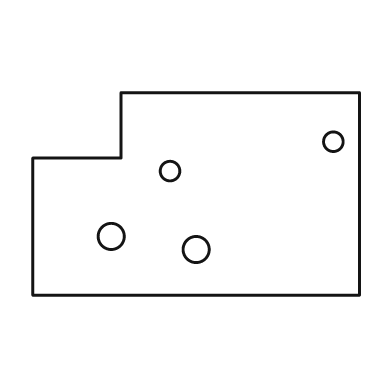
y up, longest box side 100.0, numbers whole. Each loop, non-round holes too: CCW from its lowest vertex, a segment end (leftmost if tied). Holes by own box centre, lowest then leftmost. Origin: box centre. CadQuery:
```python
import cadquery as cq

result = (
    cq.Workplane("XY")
    .moveTo(-50.0, -31.0)
    .lineTo(50.0, -31.0)
    .lineTo(50.0, 31.0)
    .lineTo(-23.0, 31.0)
    .lineTo(-23.0, 11.0)
    .lineTo(-50.0, 11.0)
    .close()
    .moveTo(0.0, -17.0)
    .circle(4.0)
    .moveTo(-26.0, -13.0)
    .circle(4.0)
    .moveTo(-8.0, 7.0)
    .circle(3.0)
    .moveTo(42.0, 16.0)
    .circle(3.0)
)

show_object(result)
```